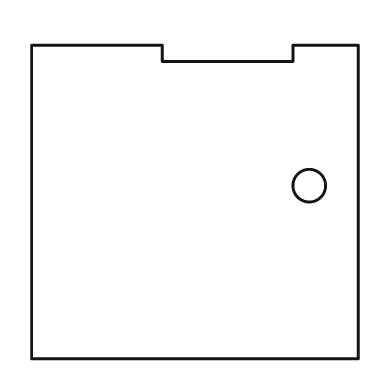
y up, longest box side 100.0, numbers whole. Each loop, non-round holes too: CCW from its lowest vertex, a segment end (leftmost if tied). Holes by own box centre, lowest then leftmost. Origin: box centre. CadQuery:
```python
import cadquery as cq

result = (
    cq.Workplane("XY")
    .moveTo(-50.0, -48.0)
    .lineTo(50.0, -48.0)
    .lineTo(50.0, 48.0)
    .lineTo(30.0, 48.0)
    .lineTo(30.0, 43.0)
    .lineTo(-10.0, 43.0)
    .lineTo(-10.0, 48.0)
    .lineTo(-50.0, 48.0)
    .close()
    .moveTo(35.0, 5.0)
    .circle(5.0)
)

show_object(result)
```